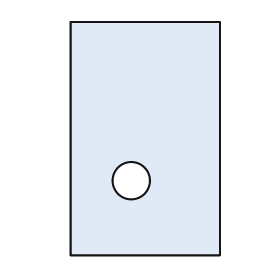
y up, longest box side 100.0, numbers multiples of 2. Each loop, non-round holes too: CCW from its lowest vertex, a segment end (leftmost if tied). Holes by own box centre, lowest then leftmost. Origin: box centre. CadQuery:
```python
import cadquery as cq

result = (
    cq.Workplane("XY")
    .moveTo(-32.0, -50.0)
    .lineTo(32.0, -50.0)
    .lineTo(32.0, 50.0)
    .lineTo(-32.0, 50.0)
    .close()
    .moveTo(-6.0, -18.0)
    .circle(8.0)
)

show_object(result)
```